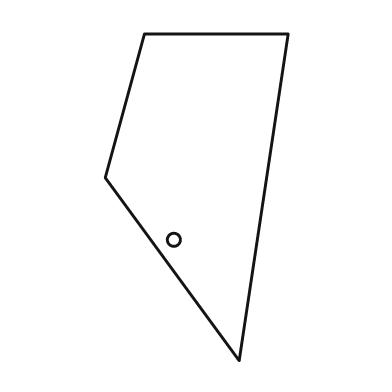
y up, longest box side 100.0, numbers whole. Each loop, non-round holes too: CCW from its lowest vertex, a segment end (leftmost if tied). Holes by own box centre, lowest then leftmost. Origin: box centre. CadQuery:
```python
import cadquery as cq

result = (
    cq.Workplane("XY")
    .moveTo(13.0, -50.0)
    .lineTo(28.0, 50.0)
    .lineTo(-16.0, 50.0)
    .lineTo(-28.0, 6.0)
    .close()
    .moveTo(-7.0, -13.0)
    .circle(2.0)
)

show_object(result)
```